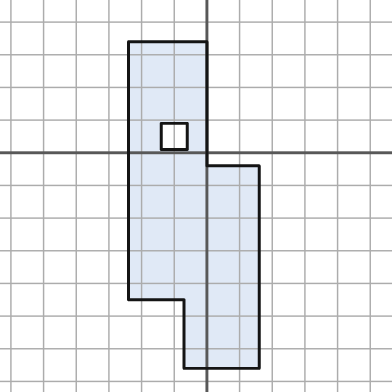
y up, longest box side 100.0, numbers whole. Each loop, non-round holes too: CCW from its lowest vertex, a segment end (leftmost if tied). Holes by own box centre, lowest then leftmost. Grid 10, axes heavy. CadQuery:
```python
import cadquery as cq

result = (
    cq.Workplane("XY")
    .moveTo(-7.0, -66.0)
    .lineTo(16.0, -66.0)
    .lineTo(16.0, -4.0)
    .lineTo(0.0, -4.0)
    .lineTo(0.0, 34.0)
    .lineTo(-24.0, 34.0)
    .lineTo(-24.0, -45.0)
    .lineTo(-7.0, -45.0)
    .close()
    .moveTo(-14.0, 1.0)
    .lineTo(-6.0, 1.0)
    .lineTo(-6.0, 9.0)
    .lineTo(-14.0, 9.0)
    .close()
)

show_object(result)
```